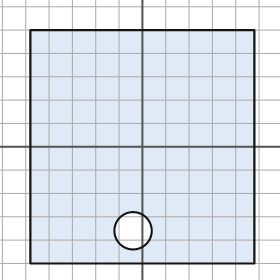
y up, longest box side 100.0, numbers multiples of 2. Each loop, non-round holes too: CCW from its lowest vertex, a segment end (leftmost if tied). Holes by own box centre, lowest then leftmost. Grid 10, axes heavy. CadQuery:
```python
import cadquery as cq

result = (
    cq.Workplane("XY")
    .moveTo(-48.0, -50.0)
    .lineTo(48.0, -50.0)
    .lineTo(48.0, 50.0)
    .lineTo(-48.0, 50.0)
    .close()
    .moveTo(-4.0, -36.0)
    .circle(8.0)
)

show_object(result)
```